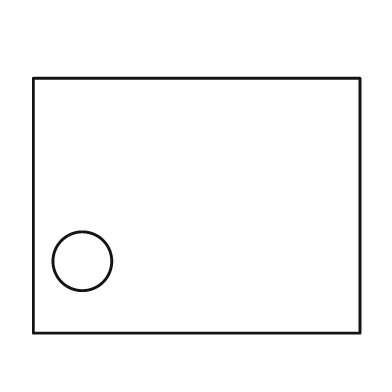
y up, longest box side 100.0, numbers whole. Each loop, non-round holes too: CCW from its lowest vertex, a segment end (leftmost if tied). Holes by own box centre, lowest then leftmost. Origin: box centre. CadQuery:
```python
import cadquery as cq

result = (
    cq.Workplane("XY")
    .moveTo(-50.0, -39.0)
    .lineTo(50.0, -39.0)
    .lineTo(50.0, 39.0)
    .lineTo(-50.0, 39.0)
    .close()
    .moveTo(-35.0, -17.0)
    .circle(9.0)
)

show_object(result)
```